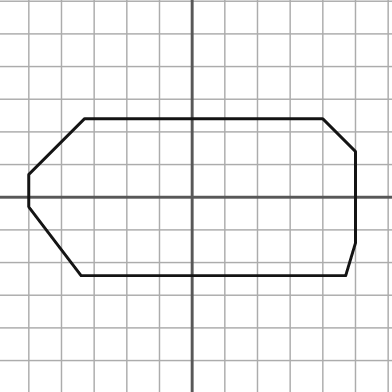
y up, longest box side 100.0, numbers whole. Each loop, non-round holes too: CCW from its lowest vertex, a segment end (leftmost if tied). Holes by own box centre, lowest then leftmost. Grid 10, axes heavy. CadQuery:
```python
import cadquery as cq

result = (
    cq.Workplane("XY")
    .moveTo(-34.0, -24.0)
    .lineTo(47.0, -24.0)
    .lineTo(50.0, -14.0)
    .lineTo(50.0, 14.0)
    .lineTo(40.0, 24.0)
    .lineTo(-33.0, 24.0)
    .lineTo(-50.0, 7.0)
    .lineTo(-50.0, -3.0)
    .close()
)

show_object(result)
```